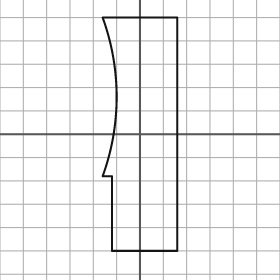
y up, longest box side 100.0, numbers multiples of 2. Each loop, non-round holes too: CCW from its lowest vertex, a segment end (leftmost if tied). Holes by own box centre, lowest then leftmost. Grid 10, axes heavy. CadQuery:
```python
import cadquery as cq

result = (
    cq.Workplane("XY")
    .moveTo(-12.0, -50.0)
    .lineTo(16.0, -50.0)
    .lineTo(16.0, 50.0)
    .lineTo(-16.0, 50.0)
    .threePointArc((-10.0, 16.0), (-16.0, -18.0))
    .lineTo(-12.0, -18.0)
    .close()
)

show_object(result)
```